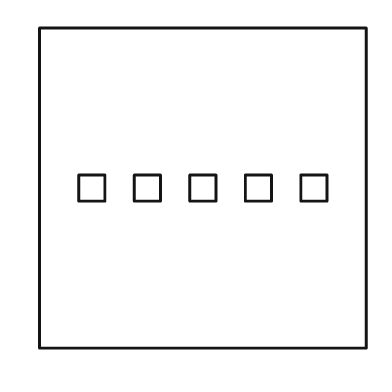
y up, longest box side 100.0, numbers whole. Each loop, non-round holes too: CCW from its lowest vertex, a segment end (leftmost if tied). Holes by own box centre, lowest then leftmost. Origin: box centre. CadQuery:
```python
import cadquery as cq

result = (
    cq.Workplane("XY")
    .moveTo(-50.0, -49.0)
    .lineTo(50.0, -49.0)
    .lineTo(50.0, 49.0)
    .lineTo(-50.0, 49.0)
    .close()
    .moveTo(-38.0, -4.0)
    .lineTo(-30.0, -4.0)
    .lineTo(-30.0, 4.0)
    .lineTo(-38.0, 4.0)
    .close()
    .moveTo(-21.0, -4.0)
    .lineTo(-13.0, -4.0)
    .lineTo(-13.0, 4.0)
    .lineTo(-21.0, 4.0)
    .close()
    .moveTo(-4.0, -4.0)
    .lineTo(4.0, -4.0)
    .lineTo(4.0, 4.0)
    .lineTo(-4.0, 4.0)
    .close()
    .moveTo(13.0, -4.0)
    .lineTo(21.0, -4.0)
    .lineTo(21.0, 4.0)
    .lineTo(13.0, 4.0)
    .close()
    .moveTo(30.0, -4.0)
    .lineTo(38.0, -4.0)
    .lineTo(38.0, 4.0)
    .lineTo(30.0, 4.0)
    .close()
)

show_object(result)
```